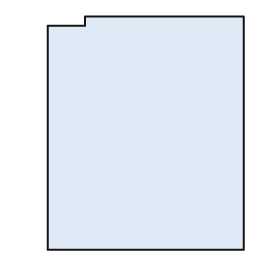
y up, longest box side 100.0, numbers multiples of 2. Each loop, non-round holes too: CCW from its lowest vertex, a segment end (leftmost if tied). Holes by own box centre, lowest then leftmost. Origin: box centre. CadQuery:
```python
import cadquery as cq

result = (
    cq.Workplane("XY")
    .moveTo(-42.0, -50.0)
    .lineTo(42.0, -50.0)
    .lineTo(42.0, 50.0)
    .lineTo(-26.0, 50.0)
    .lineTo(-26.0, 46.0)
    .lineTo(-42.0, 46.0)
    .close()
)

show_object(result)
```